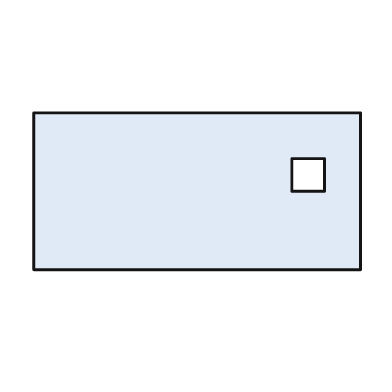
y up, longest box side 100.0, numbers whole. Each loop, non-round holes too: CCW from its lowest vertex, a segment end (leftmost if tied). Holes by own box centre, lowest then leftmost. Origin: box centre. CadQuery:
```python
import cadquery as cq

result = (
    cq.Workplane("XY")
    .moveTo(-50.0, -24.0)
    .lineTo(50.0, -24.0)
    .lineTo(50.0, 24.0)
    .lineTo(-50.0, 24.0)
    .close()
    .moveTo(29.0, 0.0)
    .lineTo(39.0, 0.0)
    .lineTo(39.0, 10.0)
    .lineTo(29.0, 10.0)
    .close()
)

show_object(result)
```